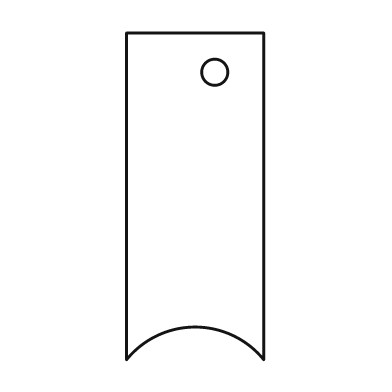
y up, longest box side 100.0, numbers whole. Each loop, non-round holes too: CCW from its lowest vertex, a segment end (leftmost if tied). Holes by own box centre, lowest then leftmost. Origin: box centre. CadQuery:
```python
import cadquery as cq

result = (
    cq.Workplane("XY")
    .moveTo(-21.0, -50.0)
    .threePointArc((0.0, -40.0), (21.0, -50.0))
    .lineTo(21.0, 50.0)
    .lineTo(-21.0, 50.0)
    .close()
    .moveTo(6.0, 38.0)
    .circle(4.0)
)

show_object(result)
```